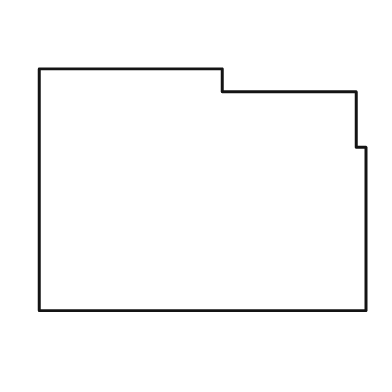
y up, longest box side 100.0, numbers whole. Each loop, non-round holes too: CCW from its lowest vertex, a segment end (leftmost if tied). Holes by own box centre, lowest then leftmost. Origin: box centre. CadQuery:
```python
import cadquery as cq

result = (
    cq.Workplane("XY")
    .moveTo(-50.0, -37.0)
    .lineTo(50.0, -37.0)
    .lineTo(50.0, 13.0)
    .lineTo(47.0, 13.0)
    .lineTo(47.0, 30.0)
    .lineTo(6.0, 30.0)
    .lineTo(6.0, 37.0)
    .lineTo(-50.0, 37.0)
    .close()
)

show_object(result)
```